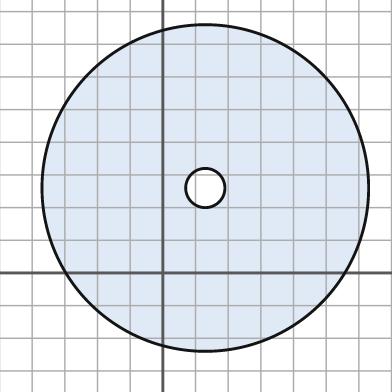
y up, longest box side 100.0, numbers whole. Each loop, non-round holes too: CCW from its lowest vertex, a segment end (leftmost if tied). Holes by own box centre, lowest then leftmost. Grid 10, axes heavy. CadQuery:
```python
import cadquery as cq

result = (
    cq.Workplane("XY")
    .moveTo(13.0, 26.0)
    .circle(50.0)
    .moveTo(13.0, 26.0)
    .circle(6.0)
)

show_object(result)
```